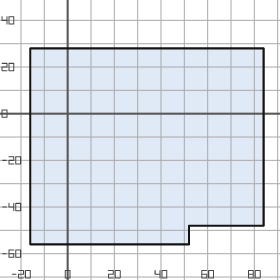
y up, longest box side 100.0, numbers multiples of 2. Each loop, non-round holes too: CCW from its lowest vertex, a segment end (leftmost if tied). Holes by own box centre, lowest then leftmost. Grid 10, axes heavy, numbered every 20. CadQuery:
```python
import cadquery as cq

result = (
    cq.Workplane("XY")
    .moveTo(-16.0, -56.0)
    .lineTo(52.0, -56.0)
    .lineTo(52.0, -48.0)
    .lineTo(84.0, -48.0)
    .lineTo(84.0, 28.0)
    .lineTo(-16.0, 28.0)
    .close()
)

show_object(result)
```